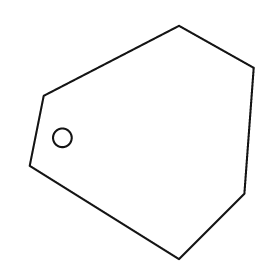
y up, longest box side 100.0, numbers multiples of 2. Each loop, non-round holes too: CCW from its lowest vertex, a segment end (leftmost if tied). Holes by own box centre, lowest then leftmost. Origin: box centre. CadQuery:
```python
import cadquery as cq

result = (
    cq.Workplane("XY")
    .moveTo(16.0, -50.0)
    .lineTo(44.0, -22.0)
    .lineTo(48.0, 32.0)
    .lineTo(16.0, 50.0)
    .lineTo(-42.0, 20.0)
    .lineTo(-48.0, -10.0)
    .close()
    .moveTo(-34.0, 2.0)
    .circle(4.0)
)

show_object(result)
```